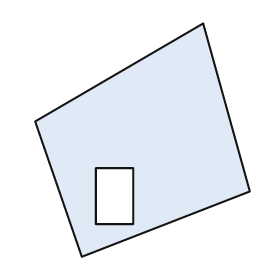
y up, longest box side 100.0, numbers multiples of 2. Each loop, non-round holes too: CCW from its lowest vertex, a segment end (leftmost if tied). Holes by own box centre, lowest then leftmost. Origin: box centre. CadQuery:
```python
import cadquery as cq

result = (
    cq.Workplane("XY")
    .moveTo(-26.0, -50.0)
    .lineTo(46.0, -22.0)
    .lineTo(26.0, 50.0)
    .lineTo(-46.0, 8.0)
    .close()
    .moveTo(-20.0, -36.0)
    .lineTo(-4.0, -36.0)
    .lineTo(-4.0, -12.0)
    .lineTo(-20.0, -12.0)
    .close()
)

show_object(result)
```